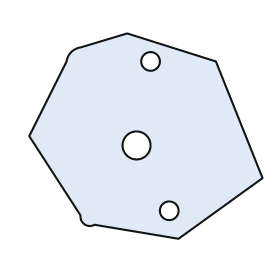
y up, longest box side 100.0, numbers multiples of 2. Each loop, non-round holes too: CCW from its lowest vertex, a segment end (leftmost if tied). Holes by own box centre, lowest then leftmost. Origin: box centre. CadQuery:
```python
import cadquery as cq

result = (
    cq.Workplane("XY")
    .moveTo(14.0, -44.0)
    .lineTo(50.0, -18.0)
    .lineTo(30.0, 32.0)
    .lineTo(-8.0, 44.0)
    .lineTo(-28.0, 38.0)
    .threePointArc((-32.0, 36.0), (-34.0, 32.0))
    .lineTo(-50.0, 0.0)
    .lineTo(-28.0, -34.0)
    .threePointArc((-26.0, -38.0), (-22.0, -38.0))
    .close()
    .moveTo(10.0, -32.0)
    .circle(4.0)
    .moveTo(-4.0, -4.0)
    .circle(6.0)
    .moveTo(2.0, 32.0)
    .circle(4.0)
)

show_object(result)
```